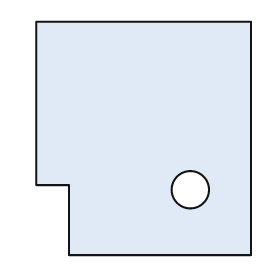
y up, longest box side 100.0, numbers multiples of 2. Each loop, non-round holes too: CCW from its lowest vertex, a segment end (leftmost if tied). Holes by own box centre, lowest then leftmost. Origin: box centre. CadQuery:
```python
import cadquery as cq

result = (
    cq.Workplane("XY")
    .moveTo(-32.0, -50.0)
    .lineTo(46.0, -50.0)
    .lineTo(46.0, 50.0)
    .lineTo(-46.0, 50.0)
    .lineTo(-46.0, -20.0)
    .lineTo(-32.0, -20.0)
    .close()
    .moveTo(20.0, -22.0)
    .circle(8.0)
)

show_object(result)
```